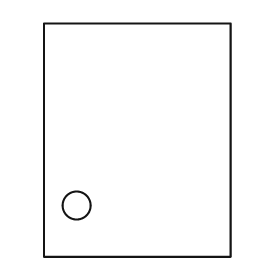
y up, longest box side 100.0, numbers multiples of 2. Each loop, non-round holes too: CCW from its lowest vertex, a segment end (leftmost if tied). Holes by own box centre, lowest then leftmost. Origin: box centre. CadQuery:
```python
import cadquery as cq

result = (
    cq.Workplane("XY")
    .moveTo(-40.0, -50.0)
    .lineTo(40.0, -50.0)
    .lineTo(40.0, 50.0)
    .lineTo(-40.0, 50.0)
    .close()
    .moveTo(-26.0, -28.0)
    .circle(6.0)
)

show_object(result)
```